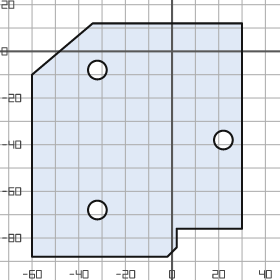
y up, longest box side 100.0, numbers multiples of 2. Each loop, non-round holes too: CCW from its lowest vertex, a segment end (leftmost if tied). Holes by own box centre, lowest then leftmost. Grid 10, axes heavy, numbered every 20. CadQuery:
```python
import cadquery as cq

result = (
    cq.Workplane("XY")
    .moveTo(-60.0, -88.0)
    .lineTo(-2.0, -88.0)
    .lineTo(2.0, -84.0)
    .lineTo(2.0, -76.0)
    .lineTo(30.0, -76.0)
    .lineTo(30.0, 12.0)
    .lineTo(-34.0, 12.0)
    .lineTo(-60.0, -10.0)
    .close()
    .moveTo(-32.0, -68.0)
    .circle(4.0)
    .moveTo(22.0, -38.0)
    .circle(4.0)
    .moveTo(-32.0, -8.0)
    .circle(4.0)
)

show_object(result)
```